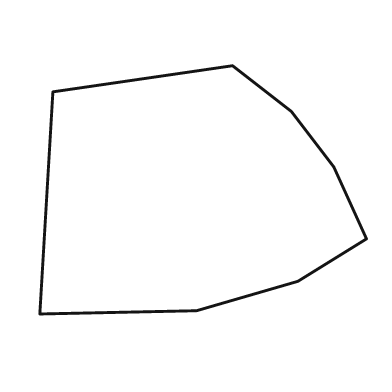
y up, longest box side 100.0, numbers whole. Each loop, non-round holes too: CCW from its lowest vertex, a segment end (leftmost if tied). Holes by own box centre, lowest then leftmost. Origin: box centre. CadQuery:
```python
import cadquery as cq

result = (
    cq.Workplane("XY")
    .moveTo(-50.0, -38.0)
    .lineTo(-2.0, -37.0)
    .lineTo(29.0, -28.0)
    .lineTo(50.0, -15.0)
    .lineTo(40.0, 7.0)
    .lineTo(27.0, 24.0)
    .lineTo(9.0, 38.0)
    .lineTo(-46.0, 30.0)
    .close()
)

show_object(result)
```